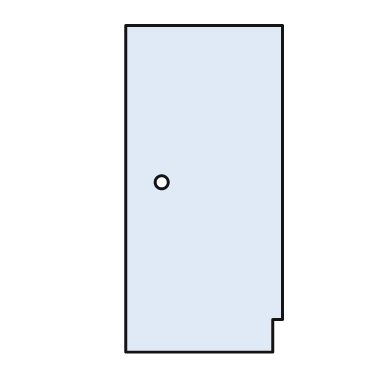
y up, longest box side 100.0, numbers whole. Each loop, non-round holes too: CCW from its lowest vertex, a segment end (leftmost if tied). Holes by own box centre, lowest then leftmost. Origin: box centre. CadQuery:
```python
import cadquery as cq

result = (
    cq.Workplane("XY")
    .moveTo(-24.0, -50.0)
    .lineTo(21.0, -50.0)
    .lineTo(21.0, -40.0)
    .lineTo(24.0, -40.0)
    .lineTo(24.0, 50.0)
    .lineTo(-24.0, 50.0)
    .close()
    .moveTo(-13.0, 2.0)
    .circle(2.0)
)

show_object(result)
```